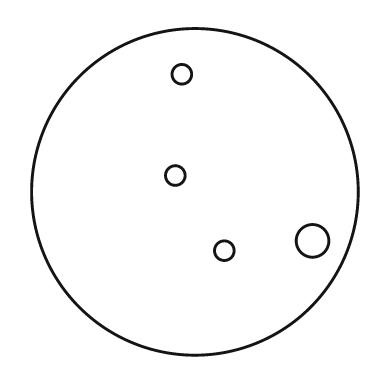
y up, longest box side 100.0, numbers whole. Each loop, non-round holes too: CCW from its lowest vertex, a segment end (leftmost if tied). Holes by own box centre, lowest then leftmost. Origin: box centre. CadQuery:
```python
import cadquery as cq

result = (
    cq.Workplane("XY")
    .moveTo(0.0, 0.0)
    .circle(50.0)
    .moveTo(9.0, -18.0)
    .circle(3.0)
    .moveTo(36.0, -15.0)
    .circle(5.0)
    .moveTo(-6.0, 5.0)
    .circle(3.0)
    .moveTo(-4.0, 36.0)
    .circle(3.0)
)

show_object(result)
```